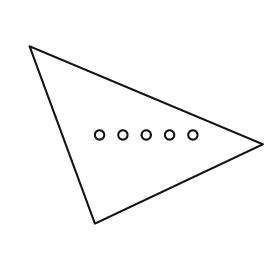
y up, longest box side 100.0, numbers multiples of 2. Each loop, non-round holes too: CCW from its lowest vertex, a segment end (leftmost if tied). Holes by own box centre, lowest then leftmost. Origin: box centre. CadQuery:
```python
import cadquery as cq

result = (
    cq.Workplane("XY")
    .moveTo(-22.0, -38.0)
    .lineTo(50.0, -4.0)
    .lineTo(-50.0, 38.0)
    .close()
    .moveTo(-20.0, 0.0)
    .circle(2.0)
    .moveTo(-10.0, 0.0)
    .circle(2.0)
    .moveTo(0.0, 0.0)
    .circle(2.0)
    .moveTo(10.0, 0.0)
    .circle(2.0)
    .moveTo(20.0, 0.0)
    .circle(2.0)
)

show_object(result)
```